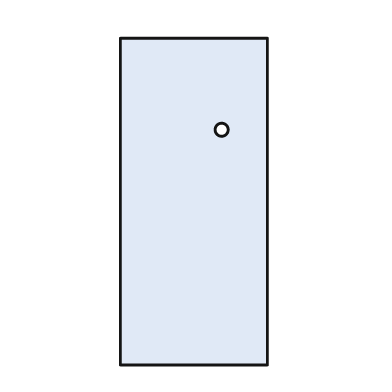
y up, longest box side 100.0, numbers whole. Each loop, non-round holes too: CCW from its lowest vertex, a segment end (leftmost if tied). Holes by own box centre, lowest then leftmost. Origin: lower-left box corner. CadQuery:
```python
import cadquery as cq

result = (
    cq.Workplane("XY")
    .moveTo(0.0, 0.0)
    .lineTo(45.0, 0.0)
    .lineTo(45.0, 100.0)
    .lineTo(0.0, 100.0)
    .close()
    .moveTo(31.0, 72.0)
    .circle(2.0)
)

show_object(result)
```